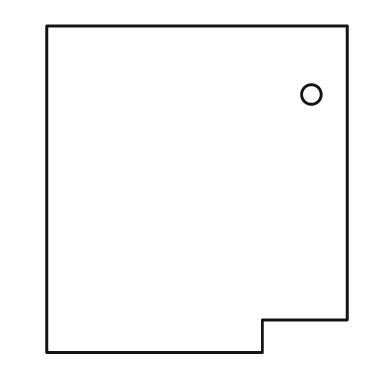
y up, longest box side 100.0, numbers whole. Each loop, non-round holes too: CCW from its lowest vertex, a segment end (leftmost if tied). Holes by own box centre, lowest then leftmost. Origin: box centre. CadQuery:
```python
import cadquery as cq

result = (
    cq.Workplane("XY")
    .moveTo(-46.0, -50.0)
    .lineTo(20.0, -50.0)
    .lineTo(20.0, -40.0)
    .lineTo(46.0, -40.0)
    .lineTo(46.0, 50.0)
    .lineTo(-46.0, 50.0)
    .close()
    .moveTo(35.0, 29.0)
    .circle(3.0)
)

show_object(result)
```